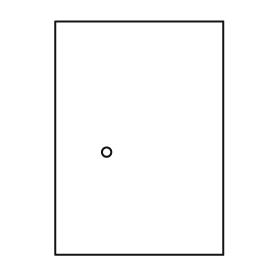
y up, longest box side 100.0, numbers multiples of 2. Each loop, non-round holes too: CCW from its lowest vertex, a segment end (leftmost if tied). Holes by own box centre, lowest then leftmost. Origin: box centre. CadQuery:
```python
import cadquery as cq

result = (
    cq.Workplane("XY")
    .moveTo(-36.0, -50.0)
    .lineTo(36.0, -50.0)
    .lineTo(36.0, 50.0)
    .lineTo(-36.0, 50.0)
    .close()
    .moveTo(-14.0, -6.0)
    .circle(2.0)
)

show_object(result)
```